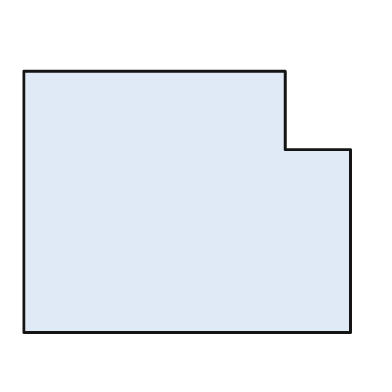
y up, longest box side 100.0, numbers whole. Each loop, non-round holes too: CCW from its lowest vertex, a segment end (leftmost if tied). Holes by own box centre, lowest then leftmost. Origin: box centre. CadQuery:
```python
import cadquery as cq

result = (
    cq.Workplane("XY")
    .moveTo(-50.0, -40.0)
    .lineTo(50.0, -40.0)
    .lineTo(50.0, 16.0)
    .lineTo(30.0, 16.0)
    .lineTo(30.0, 40.0)
    .lineTo(-50.0, 40.0)
    .close()
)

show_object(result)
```